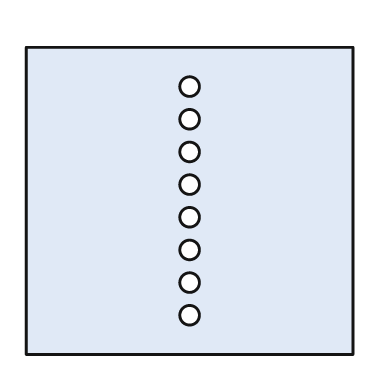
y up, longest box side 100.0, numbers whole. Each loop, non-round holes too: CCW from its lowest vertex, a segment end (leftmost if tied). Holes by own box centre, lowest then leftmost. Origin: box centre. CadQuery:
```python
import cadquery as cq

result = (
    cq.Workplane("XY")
    .moveTo(-50.0, -47.0)
    .lineTo(50.0, -47.0)
    .lineTo(50.0, 47.0)
    .lineTo(-50.0, 47.0)
    .close()
    .moveTo(0.0, -35.0)
    .circle(3.0)
    .moveTo(0.0, -25.0)
    .circle(3.0)
    .moveTo(0.0, -15.0)
    .circle(3.0)
    .moveTo(0.0, -5.0)
    .circle(3.0)
    .moveTo(0.0, 5.0)
    .circle(3.0)
    .moveTo(0.0, 15.0)
    .circle(3.0)
    .moveTo(0.0, 25.0)
    .circle(3.0)
    .moveTo(0.0, 35.0)
    .circle(3.0)
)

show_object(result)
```